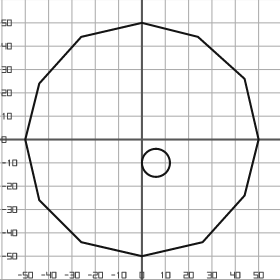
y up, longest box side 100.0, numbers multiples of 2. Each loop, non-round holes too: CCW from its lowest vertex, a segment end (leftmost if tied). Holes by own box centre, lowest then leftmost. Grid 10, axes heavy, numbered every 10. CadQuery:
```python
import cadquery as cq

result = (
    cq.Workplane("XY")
    .moveTo(0.0, -50.0)
    .lineTo(26.0, -44.0)
    .lineTo(44.0, -24.0)
    .lineTo(50.0, 0.0)
    .lineTo(44.0, 26.0)
    .lineTo(24.0, 44.0)
    .lineTo(0.0, 50.0)
    .lineTo(-26.0, 44.0)
    .lineTo(-44.0, 24.0)
    .lineTo(-50.0, 0.0)
    .lineTo(-44.0, -26.0)
    .lineTo(-26.0, -44.0)
    .close()
    .moveTo(6.0, -10.0)
    .circle(6.0)
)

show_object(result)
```